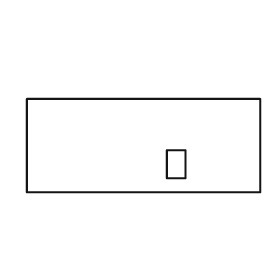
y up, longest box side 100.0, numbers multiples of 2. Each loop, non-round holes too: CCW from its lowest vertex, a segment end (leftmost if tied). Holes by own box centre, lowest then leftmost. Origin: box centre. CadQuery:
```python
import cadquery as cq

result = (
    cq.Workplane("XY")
    .moveTo(-50.0, -20.0)
    .lineTo(50.0, -20.0)
    .lineTo(50.0, 20.0)
    .lineTo(-50.0, 20.0)
    .close()
    .moveTo(10.0, -14.0)
    .lineTo(18.0, -14.0)
    .lineTo(18.0, -2.0)
    .lineTo(10.0, -2.0)
    .close()
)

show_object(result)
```